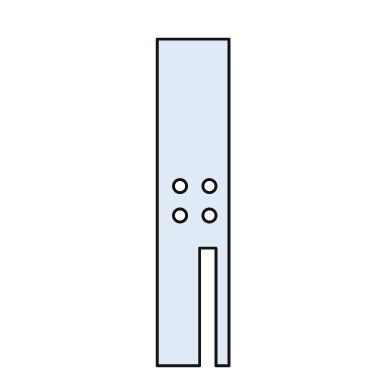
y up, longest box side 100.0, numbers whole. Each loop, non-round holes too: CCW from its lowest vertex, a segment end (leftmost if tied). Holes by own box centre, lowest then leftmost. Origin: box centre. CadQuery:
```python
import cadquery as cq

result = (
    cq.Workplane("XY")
    .moveTo(-11.0, -50.0)
    .lineTo(2.0, -50.0)
    .lineTo(2.0, -14.0)
    .lineTo(7.0, -14.0)
    .lineTo(7.0, -50.0)
    .lineTo(11.0, -50.0)
    .lineTo(11.0, 50.0)
    .lineTo(-11.0, 50.0)
    .close()
    .moveTo(-4.0, -4.0)
    .circle(2.0)
    .moveTo(5.0, -4.0)
    .circle(2.0)
    .moveTo(-4.0, 5.0)
    .circle(2.0)
    .moveTo(5.0, 5.0)
    .circle(2.0)
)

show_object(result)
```